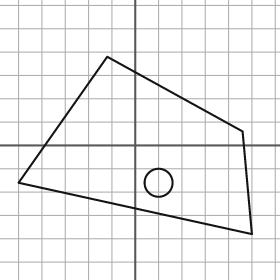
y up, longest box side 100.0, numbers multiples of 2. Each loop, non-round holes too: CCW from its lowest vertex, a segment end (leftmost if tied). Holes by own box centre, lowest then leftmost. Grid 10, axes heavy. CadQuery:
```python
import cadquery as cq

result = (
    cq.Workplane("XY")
    .moveTo(50.0, -38.0)
    .lineTo(46.0, 6.0)
    .lineTo(-12.0, 38.0)
    .lineTo(-50.0, -16.0)
    .close()
    .moveTo(10.0, -16.0)
    .circle(6.0)
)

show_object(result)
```